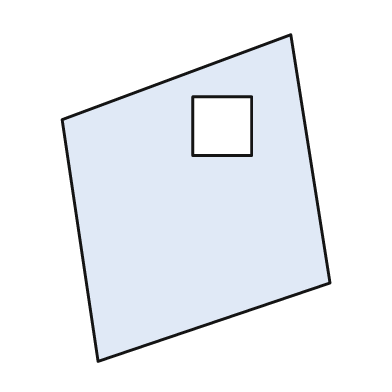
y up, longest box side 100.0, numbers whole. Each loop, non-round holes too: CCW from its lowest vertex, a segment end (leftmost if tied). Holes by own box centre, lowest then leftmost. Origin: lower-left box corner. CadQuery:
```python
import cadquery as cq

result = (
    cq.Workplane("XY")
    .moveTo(11.0, 0.0)
    .lineTo(82.0, 24.0)
    .lineTo(70.0, 100.0)
    .lineTo(0.0, 74.0)
    .close()
    .moveTo(40.0, 63.0)
    .lineTo(58.0, 63.0)
    .lineTo(58.0, 81.0)
    .lineTo(40.0, 81.0)
    .close()
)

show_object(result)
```